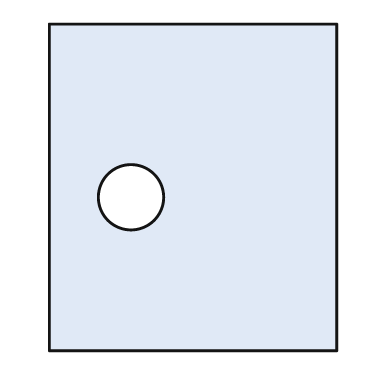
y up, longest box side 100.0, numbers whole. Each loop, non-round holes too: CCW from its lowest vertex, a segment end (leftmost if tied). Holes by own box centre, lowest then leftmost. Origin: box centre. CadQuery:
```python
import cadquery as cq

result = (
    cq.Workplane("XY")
    .moveTo(-44.0, -50.0)
    .lineTo(44.0, -50.0)
    .lineTo(44.0, 50.0)
    .lineTo(-44.0, 50.0)
    .close()
    .moveTo(-19.0, -3.0)
    .circle(10.0)
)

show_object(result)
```